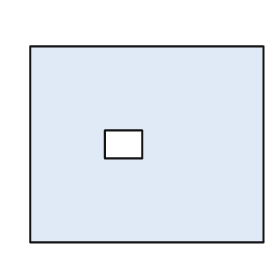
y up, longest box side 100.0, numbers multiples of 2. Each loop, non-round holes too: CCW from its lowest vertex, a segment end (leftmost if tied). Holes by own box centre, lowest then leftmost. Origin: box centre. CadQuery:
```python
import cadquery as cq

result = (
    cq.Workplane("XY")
    .moveTo(-50.0, -42.0)
    .lineTo(50.0, -42.0)
    .lineTo(50.0, 42.0)
    .lineTo(-50.0, 42.0)
    .close()
    .moveTo(-18.0, -6.0)
    .lineTo(-2.0, -6.0)
    .lineTo(-2.0, 6.0)
    .lineTo(-18.0, 6.0)
    .close()
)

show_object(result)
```